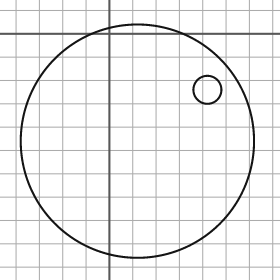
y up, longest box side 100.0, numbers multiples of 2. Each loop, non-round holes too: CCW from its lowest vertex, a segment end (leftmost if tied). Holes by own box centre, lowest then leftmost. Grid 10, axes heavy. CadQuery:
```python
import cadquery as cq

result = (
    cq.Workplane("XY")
    .moveTo(12.0, -46.0)
    .circle(50.0)
    .moveTo(42.0, -24.0)
    .circle(6.0)
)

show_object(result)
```